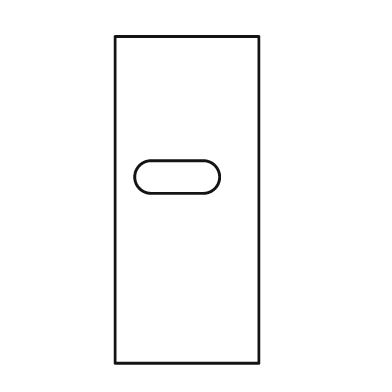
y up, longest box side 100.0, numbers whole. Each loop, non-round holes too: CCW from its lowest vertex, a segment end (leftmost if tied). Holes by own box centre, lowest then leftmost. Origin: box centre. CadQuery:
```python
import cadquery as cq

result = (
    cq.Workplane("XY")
    .moveTo(-22.0, -50.0)
    .lineTo(22.0, -50.0)
    .lineTo(22.0, 50.0)
    .lineTo(-22.0, 50.0)
    .close()
    .moveTo(-11.0, 2.0)
    .lineTo(5.0, 2.0)
    .threePointArc((10.0, 7.0), (5.0, 12.0))
    .lineTo(-11.0, 12.0)
    .threePointArc((-16.0, 7.0), (-11.0, 2.0))
    .close()
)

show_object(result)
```